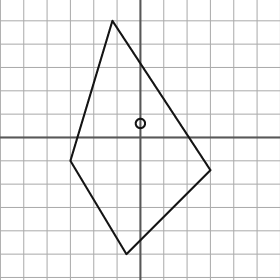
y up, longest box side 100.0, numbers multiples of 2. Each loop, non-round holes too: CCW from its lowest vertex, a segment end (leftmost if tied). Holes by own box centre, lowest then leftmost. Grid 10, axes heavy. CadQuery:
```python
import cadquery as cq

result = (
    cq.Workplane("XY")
    .moveTo(-6.0, -50.0)
    .lineTo(30.0, -14.0)
    .lineTo(-12.0, 50.0)
    .lineTo(-30.0, -10.0)
    .close()
    .moveTo(0.0, 6.0)
    .circle(2.0)
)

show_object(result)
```